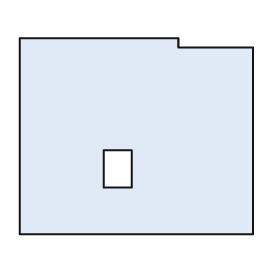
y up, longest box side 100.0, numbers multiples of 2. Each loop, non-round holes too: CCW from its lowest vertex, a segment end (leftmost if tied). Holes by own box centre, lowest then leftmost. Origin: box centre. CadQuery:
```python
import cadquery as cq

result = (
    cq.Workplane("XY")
    .moveTo(-50.0, -42.0)
    .lineTo(50.0, -42.0)
    .lineTo(50.0, 38.0)
    .lineTo(18.0, 38.0)
    .lineTo(18.0, 42.0)
    .lineTo(-50.0, 42.0)
    .close()
    .moveTo(-14.0, -22.0)
    .lineTo(-2.0, -22.0)
    .lineTo(-2.0, -6.0)
    .lineTo(-14.0, -6.0)
    .close()
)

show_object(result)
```